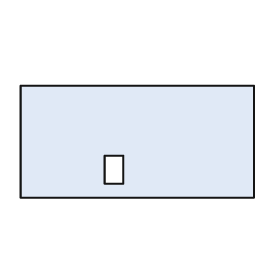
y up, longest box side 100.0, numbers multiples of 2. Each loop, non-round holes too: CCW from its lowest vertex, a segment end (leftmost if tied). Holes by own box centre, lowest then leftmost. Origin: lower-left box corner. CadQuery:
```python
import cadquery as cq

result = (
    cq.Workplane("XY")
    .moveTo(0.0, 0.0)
    .lineTo(100.0, 0.0)
    .lineTo(100.0, 48.0)
    .lineTo(0.0, 48.0)
    .close()
    .moveTo(36.0, 6.0)
    .lineTo(44.0, 6.0)
    .lineTo(44.0, 18.0)
    .lineTo(36.0, 18.0)
    .close()
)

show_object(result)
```